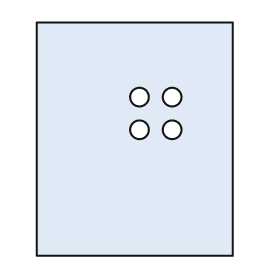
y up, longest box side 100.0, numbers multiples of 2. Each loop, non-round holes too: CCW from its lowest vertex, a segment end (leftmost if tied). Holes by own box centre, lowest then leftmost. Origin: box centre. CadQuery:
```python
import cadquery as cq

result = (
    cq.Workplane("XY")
    .moveTo(-42.0, -50.0)
    .lineTo(42.0, -50.0)
    .lineTo(42.0, 50.0)
    .lineTo(-42.0, 50.0)
    .close()
    .moveTo(2.0, 4.0)
    .circle(4.0)
    .moveTo(16.0, 4.0)
    .circle(4.0)
    .moveTo(2.0, 18.0)
    .circle(4.0)
    .moveTo(16.0, 18.0)
    .circle(4.0)
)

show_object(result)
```